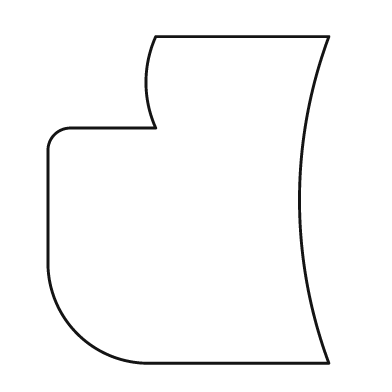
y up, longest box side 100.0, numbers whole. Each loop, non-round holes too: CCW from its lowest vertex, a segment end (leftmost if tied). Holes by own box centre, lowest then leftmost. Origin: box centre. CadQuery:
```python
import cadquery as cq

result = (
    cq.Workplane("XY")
    .moveTo(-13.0, -50.0)
    .lineTo(43.0, -50.0)
    .threePointArc((34.0, 0.0), (43.0, 50.0))
    .lineTo(-10.0, 50.0)
    .threePointArc((-13.0, 36.0), (-10.0, 22.0))
    .lineTo(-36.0, 22.0)
    .threePointArc((-41.0, 20.0), (-43.0, 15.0))
    .lineTo(-43.0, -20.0)
    .threePointArc((-34.0, -41.0), (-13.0, -50.0))
    .close()
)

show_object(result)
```